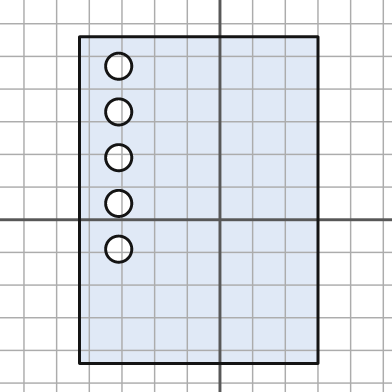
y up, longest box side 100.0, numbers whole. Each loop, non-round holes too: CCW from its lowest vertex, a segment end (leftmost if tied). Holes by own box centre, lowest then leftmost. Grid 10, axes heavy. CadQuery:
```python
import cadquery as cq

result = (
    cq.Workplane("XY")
    .moveTo(-43.0, -44.0)
    .lineTo(30.0, -44.0)
    .lineTo(30.0, 56.0)
    .lineTo(-43.0, 56.0)
    .close()
    .moveTo(-31.0, -9.0)
    .circle(4.0)
    .moveTo(-31.0, 5.0)
    .circle(4.0)
    .moveTo(-31.0, 19.0)
    .circle(4.0)
    .moveTo(-31.0, 33.0)
    .circle(4.0)
    .moveTo(-31.0, 47.0)
    .circle(4.0)
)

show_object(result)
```